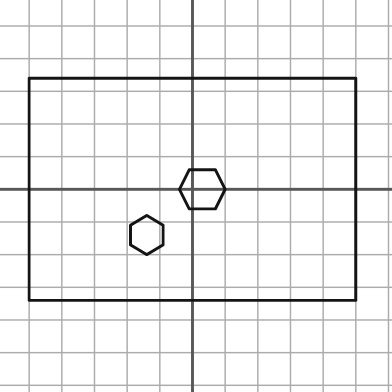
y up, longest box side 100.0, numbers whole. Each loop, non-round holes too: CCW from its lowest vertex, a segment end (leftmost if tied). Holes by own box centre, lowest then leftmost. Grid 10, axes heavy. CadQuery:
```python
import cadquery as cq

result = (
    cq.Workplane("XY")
    .moveTo(-50.0, -34.0)
    .lineTo(50.0, -34.0)
    .lineTo(50.0, 34.0)
    .lineTo(-50.0, 34.0)
    .close()
    .moveTo(-14.0, -20.0)
    .lineTo(-9.0, -17.0)
    .lineTo(-9.0, -11.0)
    .lineTo(-14.0, -8.0)
    .lineTo(-19.0, -11.0)
    .lineTo(-19.0, -17.0)
    .close()
    .moveTo(-1.0, -6.0)
    .lineTo(7.0, -6.0)
    .lineTo(10.0, 0.0)
    .lineTo(7.0, 6.0)
    .lineTo(-1.0, 6.0)
    .lineTo(-4.0, 0.0)
    .close()
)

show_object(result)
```